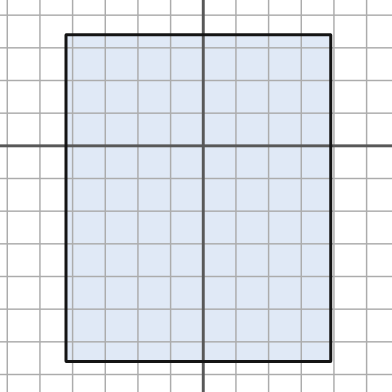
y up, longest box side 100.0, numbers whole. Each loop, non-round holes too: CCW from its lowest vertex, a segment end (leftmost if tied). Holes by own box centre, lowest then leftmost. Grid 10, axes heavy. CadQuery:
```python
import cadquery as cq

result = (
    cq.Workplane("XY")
    .moveTo(-42.0, -66.0)
    .lineTo(39.0, -66.0)
    .lineTo(39.0, 34.0)
    .lineTo(-42.0, 34.0)
    .close()
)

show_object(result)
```